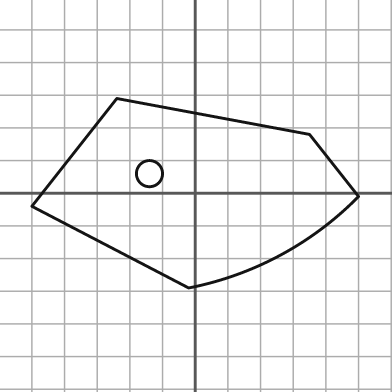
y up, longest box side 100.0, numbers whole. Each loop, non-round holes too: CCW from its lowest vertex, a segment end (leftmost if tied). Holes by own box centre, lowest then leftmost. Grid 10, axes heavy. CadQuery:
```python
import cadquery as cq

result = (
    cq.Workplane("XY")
    .moveTo(-2.0, -29.0)
    .threePointArc((26.0, -19.0), (50.0, -1.0))
    .lineTo(35.0, 18.0)
    .lineTo(-24.0, 29.0)
    .lineTo(-50.0, -4.0)
    .close()
    .moveTo(-14.0, 6.0)
    .circle(4.0)
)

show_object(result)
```